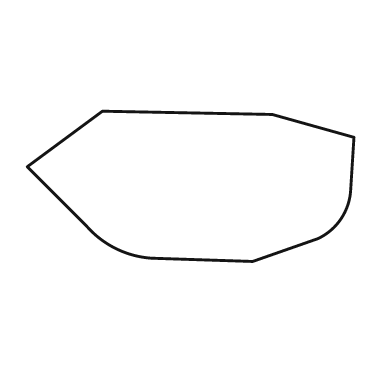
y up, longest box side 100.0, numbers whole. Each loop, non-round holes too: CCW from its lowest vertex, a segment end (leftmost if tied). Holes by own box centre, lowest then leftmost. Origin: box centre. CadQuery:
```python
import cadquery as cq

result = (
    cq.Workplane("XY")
    .moveTo(19.0, -23.0)
    .lineTo(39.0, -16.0)
    .threePointArc((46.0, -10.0), (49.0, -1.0))
    .lineTo(50.0, 15.0)
    .lineTo(25.0, 22.0)
    .lineTo(-27.0, 23.0)
    .lineTo(-50.0, 6.0)
    .lineTo(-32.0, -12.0)
    .threePointArc((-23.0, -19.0), (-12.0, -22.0))
    .close()
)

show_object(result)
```